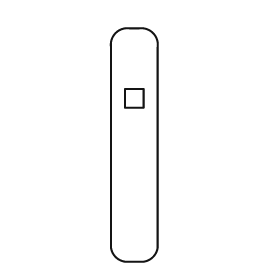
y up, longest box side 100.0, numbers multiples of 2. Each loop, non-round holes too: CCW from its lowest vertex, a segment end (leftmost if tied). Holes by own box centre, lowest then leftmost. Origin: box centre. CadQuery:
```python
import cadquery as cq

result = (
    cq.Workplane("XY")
    .moveTo(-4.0, -50.0)
    .lineTo(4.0, -50.0)
    .threePointArc((8.0, -48.0), (10.0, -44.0))
    .lineTo(10.0, 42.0)
    .threePointArc((8.0, 48.0), (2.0, 50.0))
    .lineTo(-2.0, 50.0)
    .threePointArc((-8.0, 48.0), (-10.0, 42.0))
    .lineTo(-10.0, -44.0)
    .threePointArc((-8.0, -48.0), (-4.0, -50.0))
    .close()
    .moveTo(-4.0, 16.0)
    .lineTo(4.0, 16.0)
    .lineTo(4.0, 24.0)
    .lineTo(-4.0, 24.0)
    .close()
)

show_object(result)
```